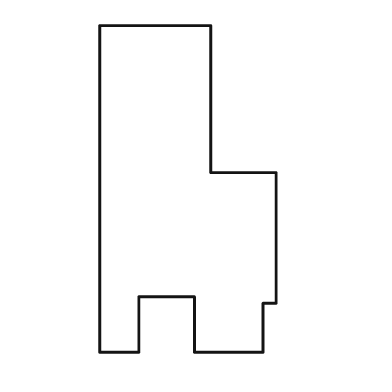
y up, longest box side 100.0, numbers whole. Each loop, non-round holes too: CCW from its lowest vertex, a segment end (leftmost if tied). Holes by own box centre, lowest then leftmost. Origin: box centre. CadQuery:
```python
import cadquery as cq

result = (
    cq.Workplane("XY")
    .moveTo(-27.0, -50.0)
    .lineTo(-15.0, -50.0)
    .lineTo(-15.0, -33.0)
    .lineTo(2.0, -33.0)
    .lineTo(2.0, -50.0)
    .lineTo(23.0, -50.0)
    .lineTo(23.0, -35.0)
    .lineTo(27.0, -35.0)
    .lineTo(27.0, 5.0)
    .lineTo(7.0, 5.0)
    .lineTo(7.0, 50.0)
    .lineTo(-27.0, 50.0)
    .close()
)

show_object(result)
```